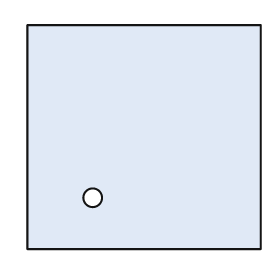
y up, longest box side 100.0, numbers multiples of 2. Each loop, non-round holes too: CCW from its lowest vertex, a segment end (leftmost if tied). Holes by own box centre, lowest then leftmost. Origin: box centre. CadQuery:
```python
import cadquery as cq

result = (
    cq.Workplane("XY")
    .moveTo(-50.0, -48.0)
    .lineTo(50.0, -48.0)
    .lineTo(50.0, 48.0)
    .lineTo(-50.0, 48.0)
    .close()
    .moveTo(-22.0, -26.0)
    .circle(4.0)
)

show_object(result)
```